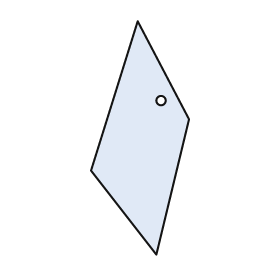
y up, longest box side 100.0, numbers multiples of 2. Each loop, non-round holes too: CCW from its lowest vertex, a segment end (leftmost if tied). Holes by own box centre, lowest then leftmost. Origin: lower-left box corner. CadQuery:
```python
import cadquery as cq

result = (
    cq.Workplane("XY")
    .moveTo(28.0, 0.0)
    .lineTo(42.0, 58.0)
    .lineTo(20.0, 100.0)
    .lineTo(0.0, 36.0)
    .close()
    .moveTo(30.0, 66.0)
    .circle(2.0)
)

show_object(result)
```